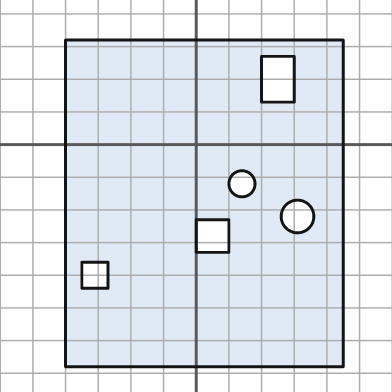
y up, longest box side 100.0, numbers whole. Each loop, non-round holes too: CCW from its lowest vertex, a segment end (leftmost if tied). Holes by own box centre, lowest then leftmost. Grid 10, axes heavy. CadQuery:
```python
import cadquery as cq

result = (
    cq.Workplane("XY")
    .moveTo(-40.0, -68.0)
    .lineTo(45.0, -68.0)
    .lineTo(45.0, 32.0)
    .lineTo(-40.0, 32.0)
    .close()
    .moveTo(-35.0, -44.0)
    .lineTo(-27.0, -44.0)
    .lineTo(-27.0, -36.0)
    .lineTo(-35.0, -36.0)
    .close()
    .moveTo(0.0, -33.0)
    .lineTo(10.0, -33.0)
    .lineTo(10.0, -23.0)
    .lineTo(0.0, -23.0)
    .close()
    .moveTo(31.0, -22.0)
    .circle(5.0)
    .moveTo(14.0, -12.0)
    .circle(4.0)
    .moveTo(20.0, 13.0)
    .lineTo(30.0, 13.0)
    .lineTo(30.0, 27.0)
    .lineTo(20.0, 27.0)
    .close()
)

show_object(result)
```